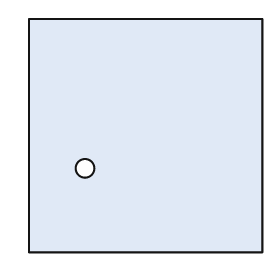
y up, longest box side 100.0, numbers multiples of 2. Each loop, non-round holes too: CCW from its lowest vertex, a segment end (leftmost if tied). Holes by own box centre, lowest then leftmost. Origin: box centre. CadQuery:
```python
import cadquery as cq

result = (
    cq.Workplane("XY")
    .moveTo(-50.0, -50.0)
    .lineTo(50.0, -50.0)
    .lineTo(50.0, 50.0)
    .lineTo(-50.0, 50.0)
    .close()
    .moveTo(-26.0, -14.0)
    .circle(4.0)
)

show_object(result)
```